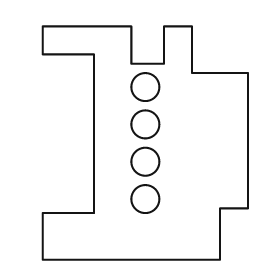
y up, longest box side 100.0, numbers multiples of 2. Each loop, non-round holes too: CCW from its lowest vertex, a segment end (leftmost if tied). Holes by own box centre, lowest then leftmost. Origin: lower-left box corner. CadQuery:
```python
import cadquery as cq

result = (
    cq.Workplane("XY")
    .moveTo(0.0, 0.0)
    .lineTo(76.0, 0.0)
    .lineTo(76.0, 22.0)
    .lineTo(88.0, 22.0)
    .lineTo(88.0, 80.0)
    .lineTo(64.0, 80.0)
    .lineTo(64.0, 100.0)
    .lineTo(52.0, 100.0)
    .lineTo(52.0, 84.0)
    .lineTo(38.0, 84.0)
    .lineTo(38.0, 100.0)
    .lineTo(0.0, 100.0)
    .lineTo(0.0, 88.0)
    .lineTo(22.0, 88.0)
    .lineTo(22.0, 20.0)
    .lineTo(0.0, 20.0)
    .close()
    .moveTo(44.0, 26.0)
    .circle(6.0)
    .moveTo(44.0, 42.0)
    .circle(6.0)
    .moveTo(44.0, 58.0)
    .circle(6.0)
    .moveTo(44.0, 74.0)
    .circle(6.0)
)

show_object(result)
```